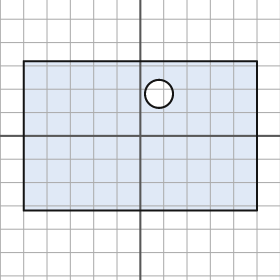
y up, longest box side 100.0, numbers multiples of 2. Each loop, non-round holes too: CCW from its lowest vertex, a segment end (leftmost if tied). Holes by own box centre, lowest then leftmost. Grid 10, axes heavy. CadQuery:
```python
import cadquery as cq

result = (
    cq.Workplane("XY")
    .moveTo(-50.0, -32.0)
    .lineTo(50.0, -32.0)
    .lineTo(50.0, 32.0)
    .lineTo(-50.0, 32.0)
    .close()
    .moveTo(8.0, 18.0)
    .circle(6.0)
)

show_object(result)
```